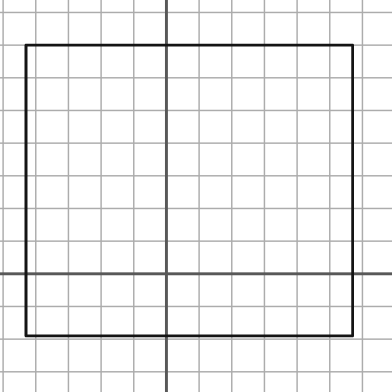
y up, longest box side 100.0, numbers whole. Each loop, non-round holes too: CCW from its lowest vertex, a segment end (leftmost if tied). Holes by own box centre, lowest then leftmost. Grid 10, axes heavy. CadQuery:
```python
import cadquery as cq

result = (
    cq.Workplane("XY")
    .moveTo(-43.0, -19.0)
    .lineTo(57.0, -19.0)
    .lineTo(57.0, 70.0)
    .lineTo(-43.0, 70.0)
    .close()
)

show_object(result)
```